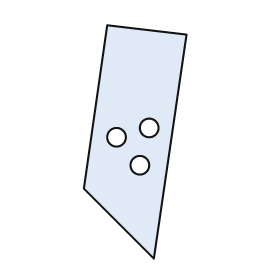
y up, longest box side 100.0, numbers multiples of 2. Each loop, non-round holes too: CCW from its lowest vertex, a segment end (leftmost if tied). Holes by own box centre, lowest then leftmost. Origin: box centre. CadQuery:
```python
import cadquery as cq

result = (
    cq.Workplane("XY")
    .moveTo(8.0, -50.0)
    .lineTo(22.0, 46.0)
    .lineTo(-12.0, 50.0)
    .lineTo(-22.0, -20.0)
    .close()
    .moveTo(2.0, -10.0)
    .circle(4.0)
    .moveTo(-8.0, 2.0)
    .circle(4.0)
    .moveTo(6.0, 6.0)
    .circle(4.0)
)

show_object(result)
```